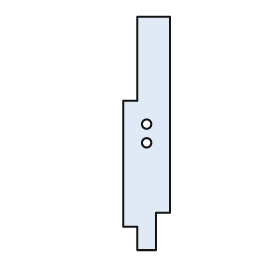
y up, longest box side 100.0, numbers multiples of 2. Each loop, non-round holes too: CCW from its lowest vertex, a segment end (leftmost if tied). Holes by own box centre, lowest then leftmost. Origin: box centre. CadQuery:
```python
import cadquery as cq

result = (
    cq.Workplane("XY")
    .moveTo(-4.0, -50.0)
    .lineTo(4.0, -50.0)
    .lineTo(4.0, -34.0)
    .lineTo(10.0, -34.0)
    .lineTo(10.0, 50.0)
    .lineTo(-4.0, 50.0)
    .lineTo(-4.0, 14.0)
    .lineTo(-10.0, 14.0)
    .lineTo(-10.0, -40.0)
    .lineTo(-4.0, -40.0)
    .close()
    .moveTo(0.0, -4.0)
    .circle(2.0)
    .moveTo(0.0, 4.0)
    .circle(2.0)
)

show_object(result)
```